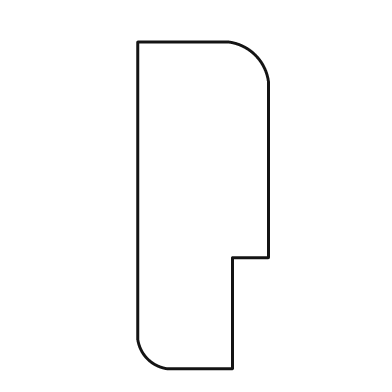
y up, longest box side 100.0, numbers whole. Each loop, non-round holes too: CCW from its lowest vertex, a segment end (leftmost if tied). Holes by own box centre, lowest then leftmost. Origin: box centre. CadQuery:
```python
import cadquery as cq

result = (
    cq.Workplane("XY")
    .moveTo(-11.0, -50.0)
    .lineTo(9.0, -50.0)
    .lineTo(9.0, -16.0)
    .lineTo(20.0, -16.0)
    .lineTo(20.0, 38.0)
    .threePointArc((16.0, 46.0), (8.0, 50.0))
    .lineTo(-20.0, 50.0)
    .lineTo(-20.0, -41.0)
    .threePointArc((-17.0, -47.0), (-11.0, -50.0))
    .close()
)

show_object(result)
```